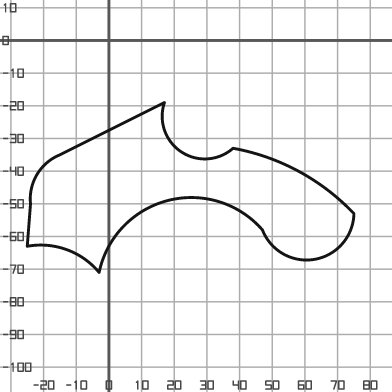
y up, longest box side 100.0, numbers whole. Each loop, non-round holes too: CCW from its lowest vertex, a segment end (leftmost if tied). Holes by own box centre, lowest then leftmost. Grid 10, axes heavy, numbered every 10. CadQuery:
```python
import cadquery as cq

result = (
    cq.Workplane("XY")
    .moveTo(-3.0, -71.0)
    .threePointArc((18.0, -49.0), (47.0, -58.0))
    .threePointArc((63.0, -67.0), (75.0, -53.0))
    .threePointArc((58.0, -40.0), (38.0, -33.0))
    .threePointArc((22.0, -34.0), (17.0, -19.0))
    .lineTo(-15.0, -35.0)
    .threePointArc((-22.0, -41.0), (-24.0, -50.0))
    .lineTo(-25.0, -63.0)
    .threePointArc((-13.0, -64.0), (-3.0, -71.0))
    .close()
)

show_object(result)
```